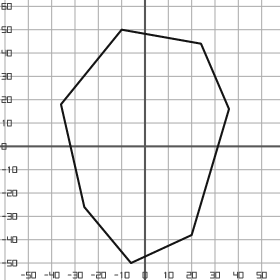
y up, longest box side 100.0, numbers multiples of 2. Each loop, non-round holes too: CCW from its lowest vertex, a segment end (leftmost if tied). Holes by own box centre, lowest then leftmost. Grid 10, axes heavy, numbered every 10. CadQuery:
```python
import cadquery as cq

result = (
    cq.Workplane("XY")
    .moveTo(-6.0, -50.0)
    .lineTo(20.0, -38.0)
    .lineTo(36.0, 16.0)
    .lineTo(24.0, 44.0)
    .lineTo(-10.0, 50.0)
    .lineTo(-36.0, 18.0)
    .lineTo(-26.0, -26.0)
    .close()
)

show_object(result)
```